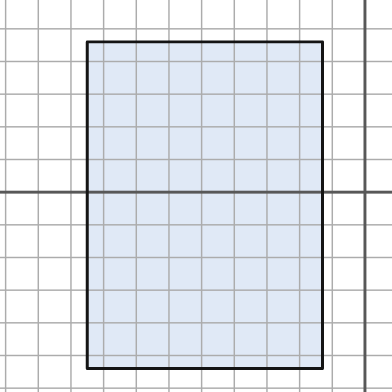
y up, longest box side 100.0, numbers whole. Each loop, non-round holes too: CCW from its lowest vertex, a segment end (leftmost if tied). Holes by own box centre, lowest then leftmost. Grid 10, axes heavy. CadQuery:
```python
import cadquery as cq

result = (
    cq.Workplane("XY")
    .moveTo(-85.0, -54.0)
    .lineTo(-13.0, -54.0)
    .lineTo(-13.0, 46.0)
    .lineTo(-85.0, 46.0)
    .close()
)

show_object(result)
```